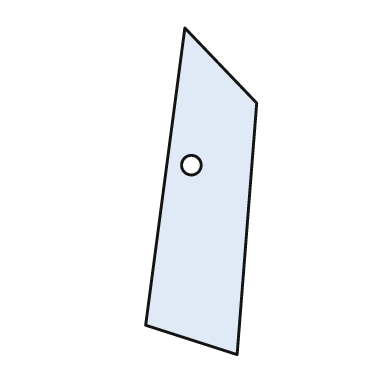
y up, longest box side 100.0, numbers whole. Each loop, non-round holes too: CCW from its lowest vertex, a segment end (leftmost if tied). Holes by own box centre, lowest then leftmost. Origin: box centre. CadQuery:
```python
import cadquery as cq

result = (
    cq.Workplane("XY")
    .moveTo(11.0, -50.0)
    .lineTo(17.0, 27.0)
    .lineTo(-5.0, 50.0)
    .lineTo(-17.0, -41.0)
    .close()
    .moveTo(-3.0, 8.0)
    .circle(3.0)
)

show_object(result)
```